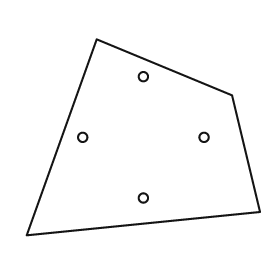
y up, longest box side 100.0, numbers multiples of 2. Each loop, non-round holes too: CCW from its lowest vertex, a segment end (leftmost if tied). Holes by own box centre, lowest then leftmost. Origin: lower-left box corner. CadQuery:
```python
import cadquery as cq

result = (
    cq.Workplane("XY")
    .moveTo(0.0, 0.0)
    .lineTo(100.0, 10.0)
    .lineTo(88.0, 60.0)
    .lineTo(30.0, 84.0)
    .close()
    .moveTo(50.0, 16.0)
    .circle(2.0)
    .moveTo(24.0, 42.0)
    .circle(2.0)
    .moveTo(76.0, 42.0)
    .circle(2.0)
    .moveTo(50.0, 68.0)
    .circle(2.0)
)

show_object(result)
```